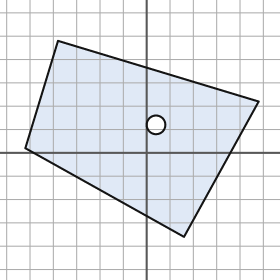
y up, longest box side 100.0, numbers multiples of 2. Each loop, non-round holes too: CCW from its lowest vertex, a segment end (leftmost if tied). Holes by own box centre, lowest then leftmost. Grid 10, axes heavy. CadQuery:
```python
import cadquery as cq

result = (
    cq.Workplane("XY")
    .moveTo(16.0, -36.0)
    .lineTo(48.0, 22.0)
    .lineTo(-38.0, 48.0)
    .lineTo(-52.0, 2.0)
    .close()
    .moveTo(4.0, 12.0)
    .circle(4.0)
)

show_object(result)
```